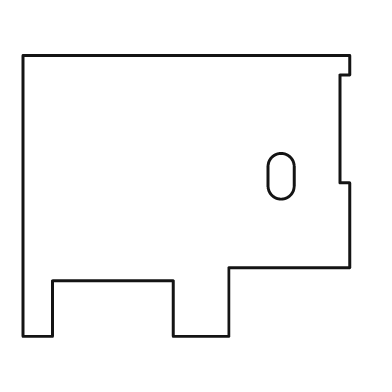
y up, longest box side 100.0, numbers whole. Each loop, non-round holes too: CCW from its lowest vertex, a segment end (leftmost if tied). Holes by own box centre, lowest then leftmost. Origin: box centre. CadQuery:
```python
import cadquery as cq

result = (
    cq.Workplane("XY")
    .moveTo(-50.0, -43.0)
    .lineTo(-41.0, -43.0)
    .lineTo(-41.0, -26.0)
    .lineTo(-4.0, -26.0)
    .lineTo(-4.0, -43.0)
    .lineTo(13.0, -43.0)
    .lineTo(13.0, -22.0)
    .lineTo(50.0, -22.0)
    .lineTo(50.0, 4.0)
    .lineTo(47.0, 4.0)
    .lineTo(47.0, 37.0)
    .lineTo(50.0, 37.0)
    .lineTo(50.0, 43.0)
    .lineTo(-50.0, 43.0)
    .close()
    .moveTo(25.0, 3.0)
    .threePointArc((29.0, -1.0), (33.0, 3.0))
    .lineTo(33.0, 9.0)
    .threePointArc((29.0, 13.0), (25.0, 9.0))
    .close()
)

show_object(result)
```